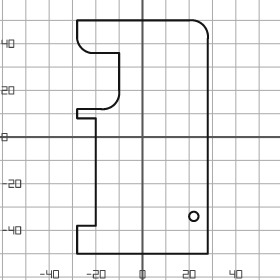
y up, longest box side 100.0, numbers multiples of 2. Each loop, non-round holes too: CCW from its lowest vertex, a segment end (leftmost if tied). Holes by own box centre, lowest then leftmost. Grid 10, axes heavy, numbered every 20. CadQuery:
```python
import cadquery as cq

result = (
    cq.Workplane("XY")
    .moveTo(-28.0, -50.0)
    .lineTo(28.0, -50.0)
    .lineTo(28.0, 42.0)
    .threePointArc((26.0, 48.0), (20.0, 50.0))
    .lineTo(-28.0, 50.0)
    .lineTo(-28.0, 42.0)
    .threePointArc((-26.0, 38.0), (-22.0, 36.0))
    .lineTo(-10.0, 36.0)
    .lineTo(-10.0, 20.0)
    .threePointArc((-12.0, 14.0), (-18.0, 12.0))
    .lineTo(-28.0, 12.0)
    .lineTo(-28.0, 8.0)
    .lineTo(-20.0, 8.0)
    .lineTo(-20.0, -38.0)
    .lineTo(-28.0, -38.0)
    .close()
    .moveTo(22.0, -34.0)
    .circle(2.0)
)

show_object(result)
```